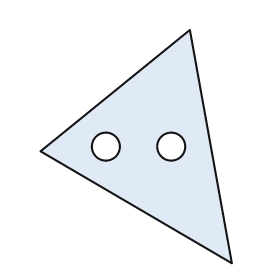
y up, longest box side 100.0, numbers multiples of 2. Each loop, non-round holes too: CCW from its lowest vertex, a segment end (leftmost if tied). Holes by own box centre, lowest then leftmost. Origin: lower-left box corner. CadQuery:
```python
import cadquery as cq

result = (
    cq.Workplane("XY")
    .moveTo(82.0, 0.0)
    .lineTo(64.0, 100.0)
    .lineTo(0.0, 48.0)
    .close()
    .moveTo(28.0, 50.0)
    .circle(6.0)
    .moveTo(56.0, 50.0)
    .circle(6.0)
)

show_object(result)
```